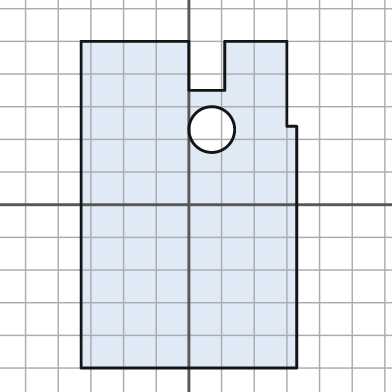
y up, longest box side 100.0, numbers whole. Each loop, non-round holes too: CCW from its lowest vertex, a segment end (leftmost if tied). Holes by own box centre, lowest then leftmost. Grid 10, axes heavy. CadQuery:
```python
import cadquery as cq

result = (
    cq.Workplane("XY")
    .moveTo(-33.0, -50.0)
    .lineTo(33.0, -50.0)
    .lineTo(33.0, 24.0)
    .lineTo(30.0, 24.0)
    .lineTo(30.0, 50.0)
    .lineTo(11.0, 50.0)
    .lineTo(11.0, 35.0)
    .lineTo(0.0, 35.0)
    .lineTo(0.0, 50.0)
    .lineTo(-33.0, 50.0)
    .close()
    .moveTo(7.0, 23.0)
    .circle(7.0)
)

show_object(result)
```